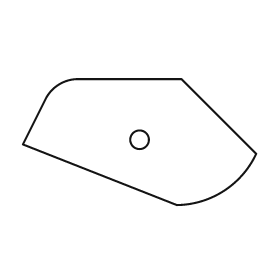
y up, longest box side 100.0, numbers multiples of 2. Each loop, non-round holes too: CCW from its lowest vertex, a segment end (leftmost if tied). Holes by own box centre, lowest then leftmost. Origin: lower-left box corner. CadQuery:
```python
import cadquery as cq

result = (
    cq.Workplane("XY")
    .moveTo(66.0, 0.0)
    .threePointArc((86.0, 6.0), (100.0, 22.0))
    .lineTo(68.0, 54.0)
    .lineTo(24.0, 54.0)
    .threePointArc((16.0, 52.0), (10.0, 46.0))
    .lineTo(0.0, 26.0)
    .close()
    .moveTo(50.0, 28.0)
    .circle(4.0)
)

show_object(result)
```